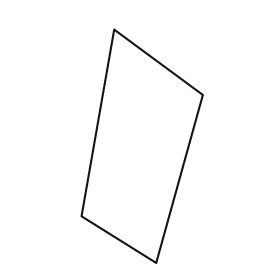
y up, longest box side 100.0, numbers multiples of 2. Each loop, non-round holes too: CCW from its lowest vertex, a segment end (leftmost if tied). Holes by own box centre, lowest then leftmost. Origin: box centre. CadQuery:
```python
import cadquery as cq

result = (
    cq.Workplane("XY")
    .moveTo(6.0, -50.0)
    .lineTo(26.0, 22.0)
    .lineTo(-12.0, 50.0)
    .lineTo(-26.0, -30.0)
    .close()
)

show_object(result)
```